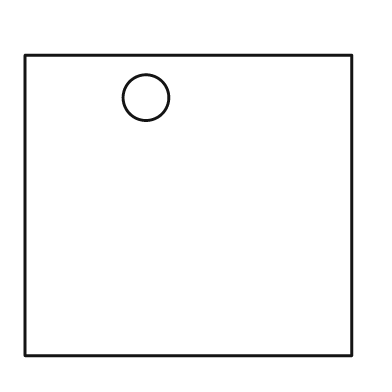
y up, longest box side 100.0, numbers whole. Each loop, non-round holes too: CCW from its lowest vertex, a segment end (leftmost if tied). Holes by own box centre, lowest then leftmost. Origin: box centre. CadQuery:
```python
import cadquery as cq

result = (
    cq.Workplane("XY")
    .moveTo(-50.0, -46.0)
    .lineTo(50.0, -46.0)
    .lineTo(50.0, 46.0)
    .lineTo(-50.0, 46.0)
    .close()
    .moveTo(-13.0, 33.0)
    .circle(7.0)
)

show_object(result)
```